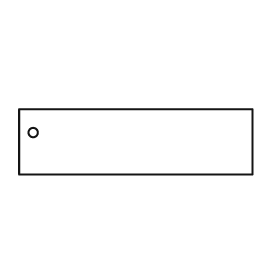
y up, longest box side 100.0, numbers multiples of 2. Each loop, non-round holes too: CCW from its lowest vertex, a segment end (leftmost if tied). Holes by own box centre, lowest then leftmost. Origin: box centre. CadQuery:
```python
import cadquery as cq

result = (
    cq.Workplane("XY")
    .moveTo(-50.0, -14.0)
    .lineTo(50.0, -14.0)
    .lineTo(50.0, 14.0)
    .lineTo(-50.0, 14.0)
    .close()
    .moveTo(-44.0, 4.0)
    .circle(2.0)
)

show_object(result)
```